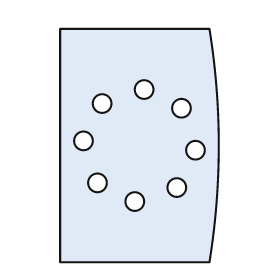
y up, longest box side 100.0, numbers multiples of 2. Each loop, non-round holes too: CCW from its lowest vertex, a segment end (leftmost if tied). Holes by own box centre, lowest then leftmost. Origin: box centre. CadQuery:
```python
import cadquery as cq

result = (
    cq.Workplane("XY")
    .moveTo(-34.0, -50.0)
    .lineTo(30.0, -50.0)
    .threePointArc((34.0, 0.0), (30.0, 50.0))
    .lineTo(-34.0, 50.0)
    .close()
    .moveTo(-2.0, -24.0)
    .circle(4.0)
    .moveTo(16.0, -18.0)
    .circle(4.0)
    .moveTo(-18.0, -16.0)
    .circle(4.0)
    .moveTo(24.0, -2.0)
    .circle(4.0)
    .moveTo(-24.0, 2.0)
    .circle(4.0)
    .moveTo(18.0, 16.0)
    .circle(4.0)
    .moveTo(-16.0, 18.0)
    .circle(4.0)
    .moveTo(2.0, 24.0)
    .circle(4.0)
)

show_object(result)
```